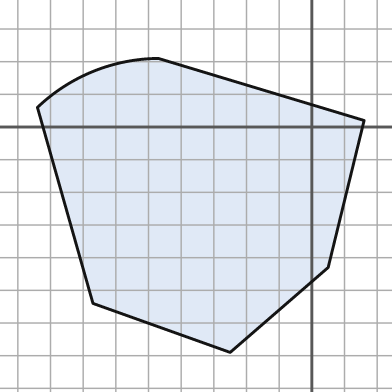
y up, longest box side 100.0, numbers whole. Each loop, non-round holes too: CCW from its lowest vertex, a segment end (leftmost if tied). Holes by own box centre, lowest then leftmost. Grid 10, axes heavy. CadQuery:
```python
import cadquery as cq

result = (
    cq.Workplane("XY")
    .moveTo(-25.0, -69.0)
    .lineTo(5.0, -43.0)
    .lineTo(16.0, 2.0)
    .lineTo(-47.0, 21.0)
    .threePointArc((-67.0, 17.0), (-84.0, 6.0))
    .lineTo(-67.0, -54.0)
    .close()
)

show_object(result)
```